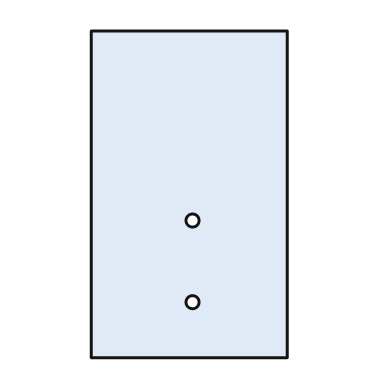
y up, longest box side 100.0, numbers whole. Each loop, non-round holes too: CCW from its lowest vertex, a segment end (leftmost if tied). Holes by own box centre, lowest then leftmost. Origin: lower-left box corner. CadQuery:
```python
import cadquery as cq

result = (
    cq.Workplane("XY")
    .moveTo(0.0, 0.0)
    .lineTo(60.0, 0.0)
    .lineTo(60.0, 100.0)
    .lineTo(0.0, 100.0)
    .close()
    .moveTo(31.0, 17.0)
    .circle(2.0)
    .moveTo(31.0, 42.0)
    .circle(2.0)
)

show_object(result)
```